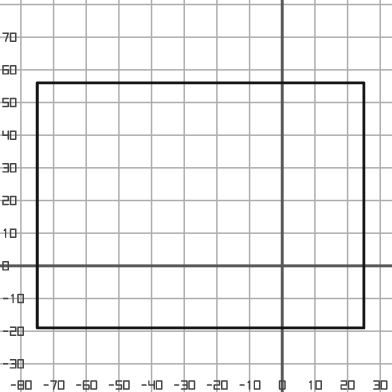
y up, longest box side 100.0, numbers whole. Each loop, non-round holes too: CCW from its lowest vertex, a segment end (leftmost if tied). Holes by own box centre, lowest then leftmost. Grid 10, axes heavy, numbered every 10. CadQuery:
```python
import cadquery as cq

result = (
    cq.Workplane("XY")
    .moveTo(-75.0, -19.0)
    .lineTo(25.0, -19.0)
    .lineTo(25.0, 56.0)
    .lineTo(-75.0, 56.0)
    .close()
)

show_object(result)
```